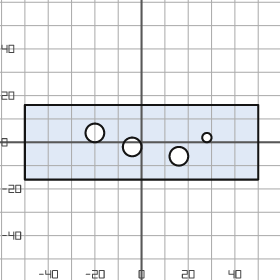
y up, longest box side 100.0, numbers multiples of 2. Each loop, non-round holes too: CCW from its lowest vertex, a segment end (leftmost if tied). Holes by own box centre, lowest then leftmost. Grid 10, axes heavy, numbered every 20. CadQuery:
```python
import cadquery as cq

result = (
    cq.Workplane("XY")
    .moveTo(-50.0, -16.0)
    .lineTo(50.0, -16.0)
    .lineTo(50.0, 16.0)
    .lineTo(-50.0, 16.0)
    .close()
    .moveTo(16.0, -6.0)
    .circle(4.0)
    .moveTo(-4.0, -2.0)
    .circle(4.0)
    .moveTo(28.0, 2.0)
    .circle(2.0)
    .moveTo(-20.0, 4.0)
    .circle(4.0)
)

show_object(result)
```